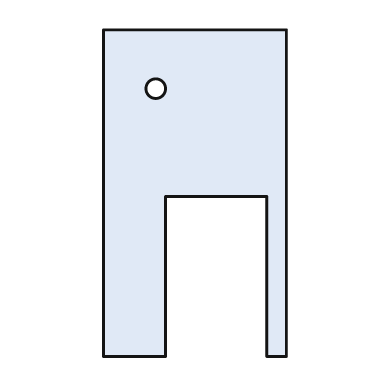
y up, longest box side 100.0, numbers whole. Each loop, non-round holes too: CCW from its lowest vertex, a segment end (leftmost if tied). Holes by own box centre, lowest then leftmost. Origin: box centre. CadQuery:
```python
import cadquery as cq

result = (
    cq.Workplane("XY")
    .moveTo(-28.0, -50.0)
    .lineTo(-9.0, -50.0)
    .lineTo(-9.0, -1.0)
    .lineTo(22.0, -1.0)
    .lineTo(22.0, -50.0)
    .lineTo(28.0, -50.0)
    .lineTo(28.0, 50.0)
    .lineTo(-28.0, 50.0)
    .close()
    .moveTo(-12.0, 32.0)
    .circle(3.0)
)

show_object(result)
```